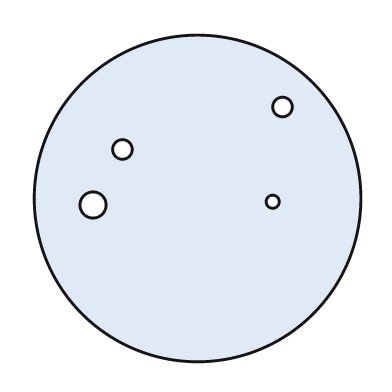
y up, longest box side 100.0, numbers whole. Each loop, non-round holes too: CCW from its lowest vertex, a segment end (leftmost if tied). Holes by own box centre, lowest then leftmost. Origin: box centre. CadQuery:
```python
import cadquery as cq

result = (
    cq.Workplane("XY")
    .moveTo(0.0, 0.0)
    .circle(50.0)
    .moveTo(-32.0, -2.0)
    .circle(4.0)
    .moveTo(23.0, -1.0)
    .circle(2.0)
    .moveTo(-23.0, 15.0)
    .circle(3.0)
    .moveTo(26.0, 28.0)
    .circle(3.0)
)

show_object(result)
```